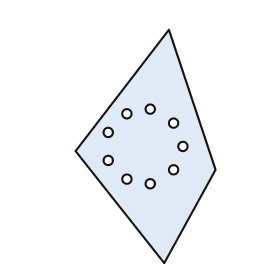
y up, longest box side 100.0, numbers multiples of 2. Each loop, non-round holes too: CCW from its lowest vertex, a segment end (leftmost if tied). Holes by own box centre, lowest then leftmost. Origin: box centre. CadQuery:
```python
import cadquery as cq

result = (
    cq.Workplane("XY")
    .moveTo(8.0, -50.0)
    .lineTo(30.0, -10.0)
    .lineTo(10.0, 50.0)
    .lineTo(-30.0, -2.0)
    .close()
    .moveTo(2.0, -16.0)
    .circle(2.0)
    .moveTo(-8.0, -14.0)
    .circle(2.0)
    .moveTo(12.0, -10.0)
    .circle(2.0)
    .moveTo(-16.0, -6.0)
    .circle(2.0)
    .moveTo(16.0, 0.0)
    .circle(2.0)
    .moveTo(-16.0, 6.0)
    .circle(2.0)
    .moveTo(12.0, 10.0)
    .circle(2.0)
    .moveTo(-8.0, 14.0)
    .circle(2.0)
    .moveTo(2.0, 16.0)
    .circle(2.0)
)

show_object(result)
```